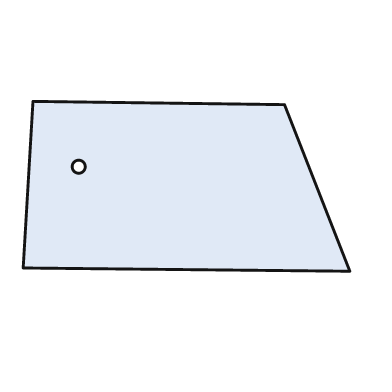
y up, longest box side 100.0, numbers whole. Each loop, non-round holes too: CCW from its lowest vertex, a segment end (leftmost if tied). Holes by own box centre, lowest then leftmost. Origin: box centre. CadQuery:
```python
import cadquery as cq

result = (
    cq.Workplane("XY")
    .moveTo(50.0, -26.0)
    .lineTo(30.0, 25.0)
    .lineTo(-47.0, 26.0)
    .lineTo(-50.0, -25.0)
    .close()
    .moveTo(-33.0, 6.0)
    .circle(2.0)
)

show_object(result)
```